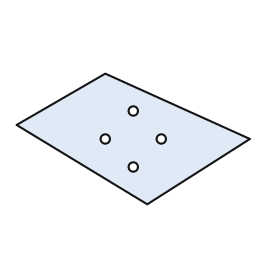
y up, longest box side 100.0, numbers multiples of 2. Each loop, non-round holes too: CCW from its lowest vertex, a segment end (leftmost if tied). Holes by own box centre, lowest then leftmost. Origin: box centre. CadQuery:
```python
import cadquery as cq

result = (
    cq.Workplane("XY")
    .moveTo(6.0, -28.0)
    .lineTo(50.0, 0.0)
    .lineTo(-12.0, 28.0)
    .lineTo(-50.0, 6.0)
    .close()
    .moveTo(0.0, -12.0)
    .circle(2.0)
    .moveTo(-12.0, 0.0)
    .circle(2.0)
    .moveTo(12.0, 0.0)
    .circle(2.0)
    .moveTo(0.0, 12.0)
    .circle(2.0)
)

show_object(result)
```